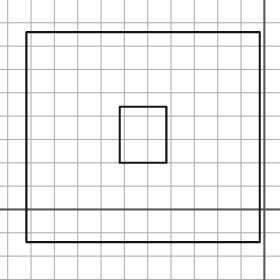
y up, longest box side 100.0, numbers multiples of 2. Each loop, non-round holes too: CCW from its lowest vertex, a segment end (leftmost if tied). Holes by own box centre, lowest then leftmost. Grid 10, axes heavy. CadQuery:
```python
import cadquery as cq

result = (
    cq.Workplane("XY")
    .moveTo(-102.0, -14.0)
    .lineTo(-2.0, -14.0)
    .lineTo(-2.0, 76.0)
    .lineTo(-102.0, 76.0)
    .close()
    .moveTo(-62.0, 20.0)
    .lineTo(-42.0, 20.0)
    .lineTo(-42.0, 44.0)
    .lineTo(-62.0, 44.0)
    .close()
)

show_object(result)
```